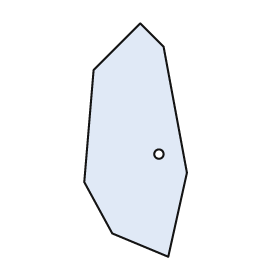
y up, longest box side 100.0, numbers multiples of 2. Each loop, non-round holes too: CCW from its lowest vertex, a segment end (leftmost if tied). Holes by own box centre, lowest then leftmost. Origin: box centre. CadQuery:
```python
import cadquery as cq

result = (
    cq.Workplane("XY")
    .moveTo(14.0, -50.0)
    .lineTo(22.0, -14.0)
    .lineTo(12.0, 40.0)
    .lineTo(2.0, 50.0)
    .lineTo(-18.0, 30.0)
    .lineTo(-22.0, -18.0)
    .lineTo(-10.0, -40.0)
    .close()
    .moveTo(10.0, -6.0)
    .circle(2.0)
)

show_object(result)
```